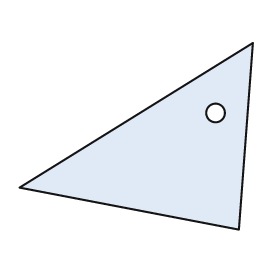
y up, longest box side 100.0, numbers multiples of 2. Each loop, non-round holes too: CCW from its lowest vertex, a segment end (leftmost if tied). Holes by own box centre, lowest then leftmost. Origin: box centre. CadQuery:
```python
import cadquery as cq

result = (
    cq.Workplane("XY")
    .moveTo(44.0, -40.0)
    .lineTo(50.0, 40.0)
    .lineTo(-50.0, -22.0)
    .close()
    .moveTo(34.0, 10.0)
    .circle(4.0)
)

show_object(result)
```